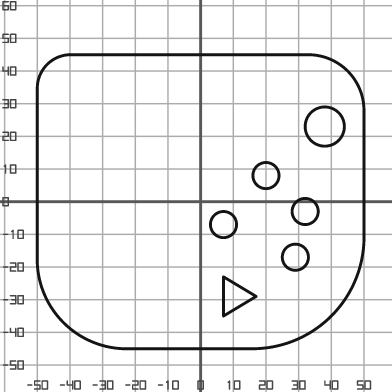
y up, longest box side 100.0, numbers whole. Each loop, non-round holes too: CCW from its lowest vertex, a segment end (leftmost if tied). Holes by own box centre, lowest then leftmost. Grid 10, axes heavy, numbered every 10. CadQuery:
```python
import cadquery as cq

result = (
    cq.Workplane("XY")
    .moveTo(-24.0, -45.0)
    .lineTo(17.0, -45.0)
    .threePointArc((40.0, -35.0), (50.0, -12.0))
    .lineTo(50.0, 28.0)
    .threePointArc((45.0, 40.0), (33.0, 45.0))
    .lineTo(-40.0, 45.0)
    .threePointArc((-47.0, 42.0), (-50.0, 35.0))
    .lineTo(-50.0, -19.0)
    .threePointArc((-42.0, -37.0), (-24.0, -45.0))
    .close()
    .moveTo(7.0, -35.0)
    .lineTo(17.0, -29.0)
    .lineTo(7.0, -23.0)
    .close()
    .moveTo(29.0, -17.0)
    .circle(4.0)
    .moveTo(7.0, -7.0)
    .circle(4.0)
    .moveTo(32.0, -3.0)
    .circle(4.0)
    .moveTo(20.0, 8.0)
    .circle(4.0)
    .moveTo(38.0, 23.0)
    .circle(6.0)
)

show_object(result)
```